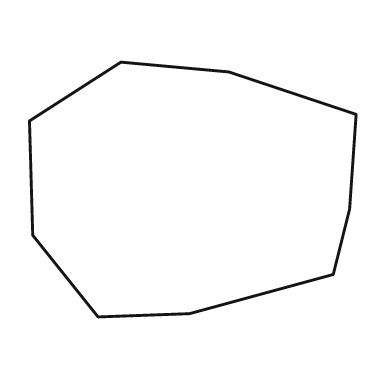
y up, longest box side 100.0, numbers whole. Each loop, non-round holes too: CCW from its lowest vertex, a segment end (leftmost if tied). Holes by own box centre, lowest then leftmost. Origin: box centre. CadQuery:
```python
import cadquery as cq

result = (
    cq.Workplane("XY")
    .moveTo(-29.0, -39.0)
    .lineTo(-1.0, -38.0)
    .lineTo(43.0, -26.0)
    .lineTo(48.0, -6.0)
    .lineTo(50.0, 23.0)
    .lineTo(11.0, 36.0)
    .lineTo(-22.0, 39.0)
    .lineTo(-50.0, 21.0)
    .lineTo(-49.0, -14.0)
    .close()
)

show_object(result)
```